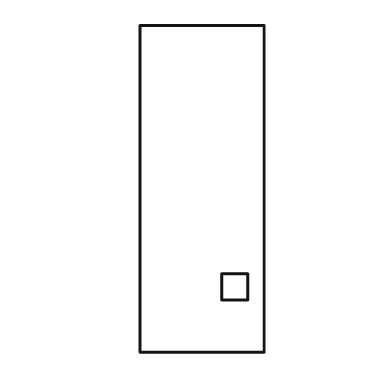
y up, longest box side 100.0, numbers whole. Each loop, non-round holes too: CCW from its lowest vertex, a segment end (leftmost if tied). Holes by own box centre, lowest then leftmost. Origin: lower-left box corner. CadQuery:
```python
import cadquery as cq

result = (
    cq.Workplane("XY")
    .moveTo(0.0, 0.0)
    .lineTo(38.0, 0.0)
    .lineTo(38.0, 100.0)
    .lineTo(0.0, 100.0)
    .close()
    .moveTo(25.0, 16.0)
    .lineTo(33.0, 16.0)
    .lineTo(33.0, 24.0)
    .lineTo(25.0, 24.0)
    .close()
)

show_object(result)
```